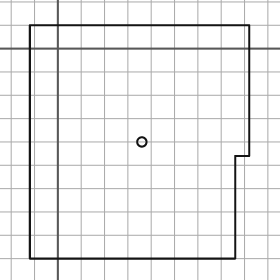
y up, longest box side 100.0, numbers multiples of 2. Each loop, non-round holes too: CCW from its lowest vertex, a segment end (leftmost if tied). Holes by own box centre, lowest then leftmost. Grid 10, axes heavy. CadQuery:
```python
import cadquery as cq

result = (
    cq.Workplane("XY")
    .moveTo(-12.0, -90.0)
    .lineTo(76.0, -90.0)
    .lineTo(76.0, -46.0)
    .lineTo(82.0, -46.0)
    .lineTo(82.0, 10.0)
    .lineTo(-12.0, 10.0)
    .close()
    .moveTo(36.0, -40.0)
    .circle(2.0)
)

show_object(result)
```